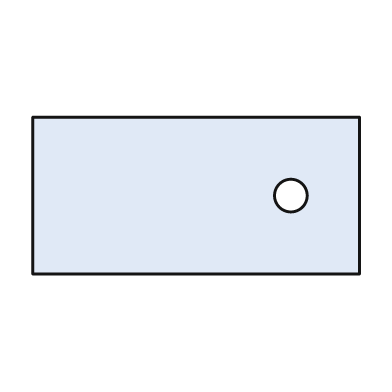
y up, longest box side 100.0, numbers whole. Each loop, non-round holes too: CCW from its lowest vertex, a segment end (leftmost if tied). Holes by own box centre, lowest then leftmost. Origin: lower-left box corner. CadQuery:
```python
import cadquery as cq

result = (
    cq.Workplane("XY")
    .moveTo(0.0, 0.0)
    .lineTo(100.0, 0.0)
    .lineTo(100.0, 48.0)
    .lineTo(0.0, 48.0)
    .close()
    .moveTo(79.0, 24.0)
    .circle(5.0)
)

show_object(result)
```